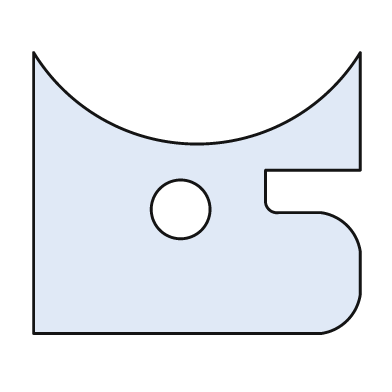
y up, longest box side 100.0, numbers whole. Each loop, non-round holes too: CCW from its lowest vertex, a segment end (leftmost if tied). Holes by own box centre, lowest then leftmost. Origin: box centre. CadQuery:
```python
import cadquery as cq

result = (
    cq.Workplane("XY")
    .moveTo(-50.0, -43.0)
    .lineTo(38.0, -43.0)
    .threePointArc((46.0, -39.0), (50.0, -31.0))
    .lineTo(50.0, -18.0)
    .threePointArc((46.0, -10.0), (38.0, -6.0))
    .lineTo(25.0, -6.0)
    .threePointArc((22.0, -5.0), (21.0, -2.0))
    .lineTo(21.0, 7.0)
    .lineTo(50.0, 7.0)
    .lineTo(50.0, 43.0)
    .threePointArc((0.0, 15.0), (-50.0, 43.0))
    .close()
    .moveTo(-5.0, -5.0)
    .circle(9.0)
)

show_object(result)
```